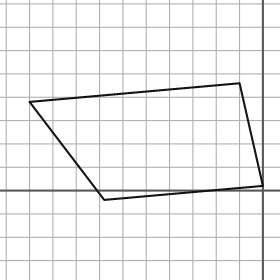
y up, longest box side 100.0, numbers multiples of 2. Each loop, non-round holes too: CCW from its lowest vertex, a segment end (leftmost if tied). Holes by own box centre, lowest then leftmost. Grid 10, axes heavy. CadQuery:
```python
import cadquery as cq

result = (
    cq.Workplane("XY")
    .moveTo(-68.0, -4.0)
    .lineTo(0.0, 2.0)
    .lineTo(-10.0, 46.0)
    .lineTo(-100.0, 38.0)
    .close()
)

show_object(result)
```